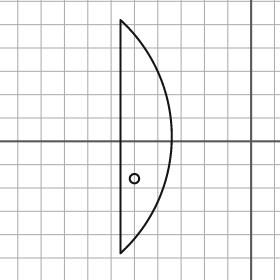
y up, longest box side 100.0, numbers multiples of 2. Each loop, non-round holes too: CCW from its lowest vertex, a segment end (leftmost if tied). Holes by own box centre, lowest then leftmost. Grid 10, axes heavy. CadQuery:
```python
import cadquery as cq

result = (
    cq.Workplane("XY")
    .moveTo(-56.0, -48.0)
    .threePointArc((-34.0, 2.0), (-56.0, 52.0))
    .close()
    .moveTo(-50.0, -16.0)
    .circle(2.0)
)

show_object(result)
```